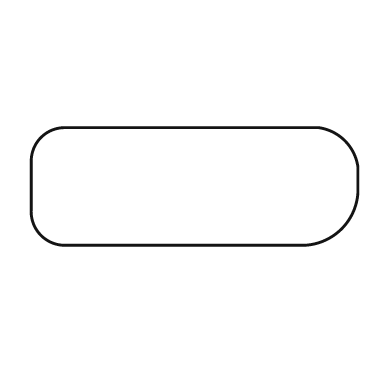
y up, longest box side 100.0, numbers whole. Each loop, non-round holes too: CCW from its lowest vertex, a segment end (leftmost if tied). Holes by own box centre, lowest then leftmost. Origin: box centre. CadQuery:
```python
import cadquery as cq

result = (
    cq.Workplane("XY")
    .moveTo(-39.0, -18.0)
    .lineTo(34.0, -18.0)
    .threePointArc((45.0, -13.0), (50.0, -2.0))
    .lineTo(50.0, 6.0)
    .threePointArc((46.0, 14.0), (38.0, 18.0))
    .lineTo(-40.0, 18.0)
    .threePointArc((-47.0, 15.0), (-50.0, 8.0))
    .lineTo(-50.0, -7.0)
    .threePointArc((-47.0, -15.0), (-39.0, -18.0))
    .close()
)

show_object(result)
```